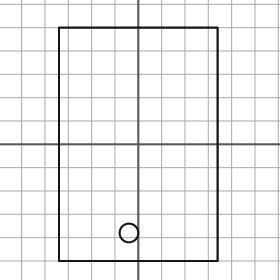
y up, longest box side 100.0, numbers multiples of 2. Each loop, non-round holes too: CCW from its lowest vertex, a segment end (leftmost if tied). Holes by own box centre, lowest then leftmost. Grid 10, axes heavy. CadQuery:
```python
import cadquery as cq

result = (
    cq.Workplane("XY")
    .moveTo(-34.0, -50.0)
    .lineTo(34.0, -50.0)
    .lineTo(34.0, 50.0)
    .lineTo(-34.0, 50.0)
    .close()
    .moveTo(-4.0, -38.0)
    .circle(4.0)
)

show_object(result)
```